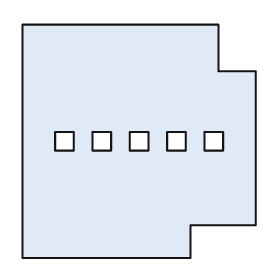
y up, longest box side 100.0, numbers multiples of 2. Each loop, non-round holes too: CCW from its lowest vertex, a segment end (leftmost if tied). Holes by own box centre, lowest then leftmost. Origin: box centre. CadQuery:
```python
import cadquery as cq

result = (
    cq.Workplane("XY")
    .moveTo(-50.0, -50.0)
    .lineTo(22.0, -50.0)
    .lineTo(22.0, -36.0)
    .lineTo(50.0, -36.0)
    .lineTo(50.0, 30.0)
    .lineTo(34.0, 30.0)
    .lineTo(34.0, 50.0)
    .lineTo(-50.0, 50.0)
    .close()
    .moveTo(-36.0, -4.0)
    .lineTo(-28.0, -4.0)
    .lineTo(-28.0, 4.0)
    .lineTo(-36.0, 4.0)
    .close()
    .moveTo(-20.0, -4.0)
    .lineTo(-12.0, -4.0)
    .lineTo(-12.0, 4.0)
    .lineTo(-20.0, 4.0)
    .close()
    .moveTo(-4.0, -4.0)
    .lineTo(4.0, -4.0)
    .lineTo(4.0, 4.0)
    .lineTo(-4.0, 4.0)
    .close()
    .moveTo(12.0, -4.0)
    .lineTo(20.0, -4.0)
    .lineTo(20.0, 4.0)
    .lineTo(12.0, 4.0)
    .close()
    .moveTo(28.0, -4.0)
    .lineTo(36.0, -4.0)
    .lineTo(36.0, 4.0)
    .lineTo(28.0, 4.0)
    .close()
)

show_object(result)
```